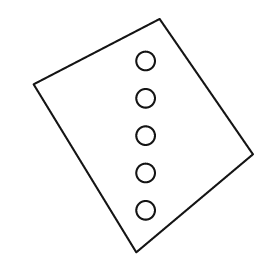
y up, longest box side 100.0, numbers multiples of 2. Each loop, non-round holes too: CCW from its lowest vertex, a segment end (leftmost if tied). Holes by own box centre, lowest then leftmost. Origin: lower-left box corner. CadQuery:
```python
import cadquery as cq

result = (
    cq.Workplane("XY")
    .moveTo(44.0, 0.0)
    .lineTo(94.0, 42.0)
    .lineTo(54.0, 100.0)
    .lineTo(0.0, 72.0)
    .close()
    .moveTo(48.0, 18.0)
    .circle(4.0)
    .moveTo(48.0, 34.0)
    .circle(4.0)
    .moveTo(48.0, 50.0)
    .circle(4.0)
    .moveTo(48.0, 66.0)
    .circle(4.0)
    .moveTo(48.0, 82.0)
    .circle(4.0)
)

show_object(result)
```